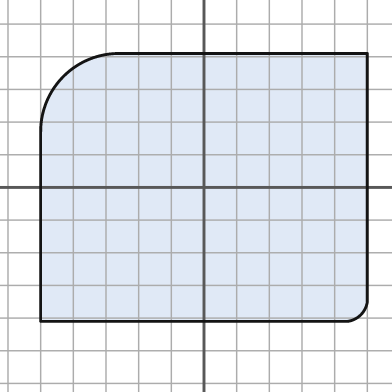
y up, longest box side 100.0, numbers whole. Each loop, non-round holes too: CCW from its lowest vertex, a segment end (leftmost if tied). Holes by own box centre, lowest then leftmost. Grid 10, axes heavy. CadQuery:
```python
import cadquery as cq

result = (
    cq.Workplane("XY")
    .moveTo(-50.0, -41.0)
    .lineTo(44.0, -41.0)
    .threePointArc((48.0, -39.0), (50.0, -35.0))
    .lineTo(50.0, 41.0)
    .lineTo(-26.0, 41.0)
    .threePointArc((-43.0, 34.0), (-50.0, 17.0))
    .close()
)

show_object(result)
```